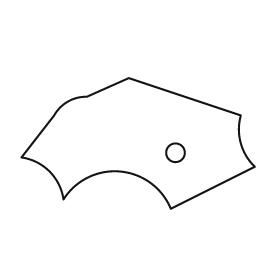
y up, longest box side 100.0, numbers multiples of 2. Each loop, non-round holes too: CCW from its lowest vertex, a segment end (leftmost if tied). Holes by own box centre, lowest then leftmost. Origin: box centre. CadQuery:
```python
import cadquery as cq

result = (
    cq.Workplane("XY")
    .moveTo(14.0, -28.0)
    .lineTo(50.0, -10.0)
    .threePointArc((44.0, 0.0), (44.0, 12.0))
    .lineTo(-4.0, 28.0)
    .lineTo(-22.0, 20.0)
    .threePointArc((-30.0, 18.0), (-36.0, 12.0))
    .lineTo(-50.0, -6.0)
    .threePointArc((-38.0, -12.0), (-32.0, -24.0))
    .threePointArc((-8.0, -12.0), (14.0, -28.0))
    .close()
    .moveTo(16.0, -4.0)
    .circle(4.0)
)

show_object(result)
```